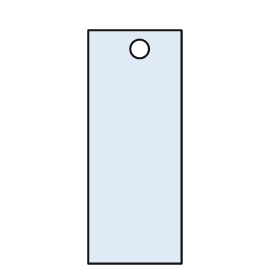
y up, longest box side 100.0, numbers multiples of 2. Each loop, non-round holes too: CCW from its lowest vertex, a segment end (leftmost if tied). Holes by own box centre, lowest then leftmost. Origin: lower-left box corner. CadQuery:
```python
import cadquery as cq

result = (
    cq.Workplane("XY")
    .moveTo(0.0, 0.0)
    .lineTo(40.0, 0.0)
    .lineTo(40.0, 100.0)
    .lineTo(0.0, 100.0)
    .close()
    .moveTo(22.0, 92.0)
    .circle(4.0)
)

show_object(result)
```